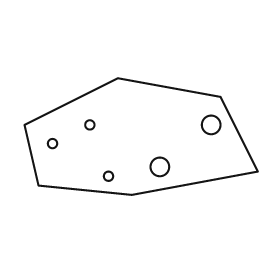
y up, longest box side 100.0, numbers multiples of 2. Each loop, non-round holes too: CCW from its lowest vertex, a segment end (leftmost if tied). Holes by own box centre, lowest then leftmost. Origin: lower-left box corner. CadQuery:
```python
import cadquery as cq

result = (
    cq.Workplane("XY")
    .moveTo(46.0, 0.0)
    .lineTo(100.0, 10.0)
    .lineTo(84.0, 42.0)
    .lineTo(40.0, 50.0)
    .lineTo(0.0, 30.0)
    .lineTo(6.0, 4.0)
    .close()
    .moveTo(36.0, 8.0)
    .circle(2.0)
    .moveTo(58.0, 12.0)
    .circle(4.0)
    .moveTo(12.0, 22.0)
    .circle(2.0)
    .moveTo(28.0, 30.0)
    .circle(2.0)
    .moveTo(80.0, 30.0)
    .circle(4.0)
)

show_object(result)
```